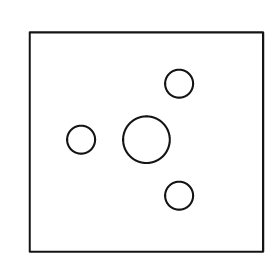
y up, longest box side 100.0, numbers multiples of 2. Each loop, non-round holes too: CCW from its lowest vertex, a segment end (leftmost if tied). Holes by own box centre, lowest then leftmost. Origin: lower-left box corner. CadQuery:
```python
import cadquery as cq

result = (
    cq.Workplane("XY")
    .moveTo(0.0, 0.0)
    .lineTo(100.0, 0.0)
    .lineTo(100.0, 94.0)
    .lineTo(0.0, 94.0)
    .close()
    .moveTo(64.0, 24.0)
    .circle(6.0)
    .moveTo(22.0, 48.0)
    .circle(6.0)
    .moveTo(50.0, 48.0)
    .circle(10.0)
    .moveTo(64.0, 72.0)
    .circle(6.0)
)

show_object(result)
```